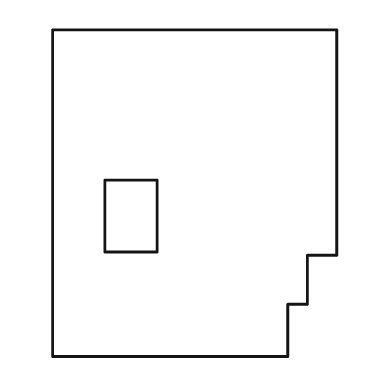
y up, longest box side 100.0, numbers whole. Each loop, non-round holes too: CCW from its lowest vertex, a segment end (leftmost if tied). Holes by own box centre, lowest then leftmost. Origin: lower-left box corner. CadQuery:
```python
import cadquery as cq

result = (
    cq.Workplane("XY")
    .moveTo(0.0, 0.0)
    .lineTo(72.0, 0.0)
    .lineTo(72.0, 16.0)
    .lineTo(78.0, 16.0)
    .lineTo(78.0, 31.0)
    .lineTo(87.0, 31.0)
    .lineTo(87.0, 100.0)
    .lineTo(0.0, 100.0)
    .close()
    .moveTo(16.0, 32.0)
    .lineTo(32.0, 32.0)
    .lineTo(32.0, 54.0)
    .lineTo(16.0, 54.0)
    .close()
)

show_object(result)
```